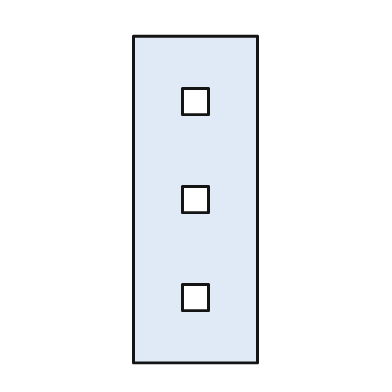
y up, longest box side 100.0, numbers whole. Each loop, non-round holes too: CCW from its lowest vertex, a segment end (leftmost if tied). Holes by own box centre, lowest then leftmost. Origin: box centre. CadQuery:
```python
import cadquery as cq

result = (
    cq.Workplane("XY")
    .moveTo(-19.0, -50.0)
    .lineTo(19.0, -50.0)
    .lineTo(19.0, 50.0)
    .lineTo(-19.0, 50.0)
    .close()
    .moveTo(-4.0, -34.0)
    .lineTo(4.0, -34.0)
    .lineTo(4.0, -26.0)
    .lineTo(-4.0, -26.0)
    .close()
    .moveTo(-4.0, -4.0)
    .lineTo(4.0, -4.0)
    .lineTo(4.0, 4.0)
    .lineTo(-4.0, 4.0)
    .close()
    .moveTo(-4.0, 26.0)
    .lineTo(4.0, 26.0)
    .lineTo(4.0, 34.0)
    .lineTo(-4.0, 34.0)
    .close()
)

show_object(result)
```